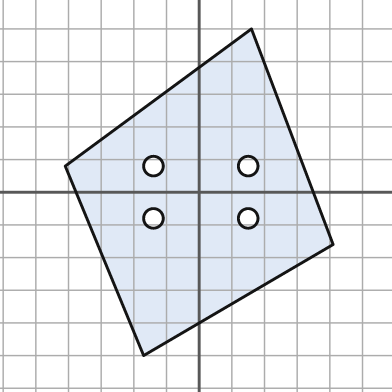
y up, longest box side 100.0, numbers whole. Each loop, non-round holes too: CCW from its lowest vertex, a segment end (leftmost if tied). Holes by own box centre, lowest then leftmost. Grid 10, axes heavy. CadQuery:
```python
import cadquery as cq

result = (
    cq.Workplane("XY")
    .moveTo(-17.0, -50.0)
    .lineTo(41.0, -16.0)
    .lineTo(16.0, 50.0)
    .lineTo(-41.0, 8.0)
    .close()
    .moveTo(-14.0, -8.0)
    .circle(3.0)
    .moveTo(15.0, -8.0)
    .circle(3.0)
    .moveTo(-14.0, 8.0)
    .circle(3.0)
    .moveTo(15.0, 8.0)
    .circle(3.0)
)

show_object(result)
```